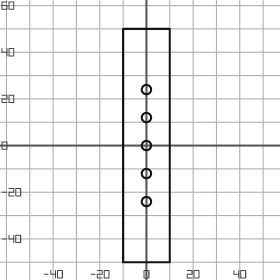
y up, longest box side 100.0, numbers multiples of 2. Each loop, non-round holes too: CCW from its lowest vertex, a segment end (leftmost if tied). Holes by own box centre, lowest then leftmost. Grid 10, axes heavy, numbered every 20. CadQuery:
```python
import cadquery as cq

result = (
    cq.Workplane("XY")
    .moveTo(-10.0, -50.0)
    .lineTo(10.0, -50.0)
    .lineTo(10.0, 50.0)
    .lineTo(-10.0, 50.0)
    .close()
    .moveTo(0.0, -24.0)
    .circle(2.0)
    .moveTo(0.0, -12.0)
    .circle(2.0)
    .moveTo(0.0, 0.0)
    .circle(2.0)
    .moveTo(0.0, 12.0)
    .circle(2.0)
    .moveTo(0.0, 24.0)
    .circle(2.0)
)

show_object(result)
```